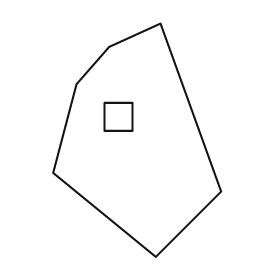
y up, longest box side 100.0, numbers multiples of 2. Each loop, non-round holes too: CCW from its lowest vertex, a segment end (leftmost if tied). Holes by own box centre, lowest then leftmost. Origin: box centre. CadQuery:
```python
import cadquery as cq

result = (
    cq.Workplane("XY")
    .moveTo(8.0, -50.0)
    .lineTo(36.0, -22.0)
    .lineTo(10.0, 50.0)
    .lineTo(-12.0, 40.0)
    .lineTo(-26.0, 24.0)
    .lineTo(-36.0, -14.0)
    .close()
    .moveTo(-14.0, 4.0)
    .lineTo(-2.0, 4.0)
    .lineTo(-2.0, 16.0)
    .lineTo(-14.0, 16.0)
    .close()
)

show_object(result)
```